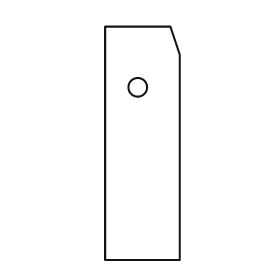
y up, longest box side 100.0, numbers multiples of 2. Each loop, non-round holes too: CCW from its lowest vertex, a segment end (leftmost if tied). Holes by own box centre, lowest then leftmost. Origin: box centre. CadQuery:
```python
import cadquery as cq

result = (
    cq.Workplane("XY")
    .moveTo(-16.0, -50.0)
    .lineTo(16.0, -50.0)
    .lineTo(16.0, 38.0)
    .lineTo(12.0, 50.0)
    .lineTo(-16.0, 50.0)
    .close()
    .moveTo(-2.0, 24.0)
    .circle(4.0)
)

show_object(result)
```